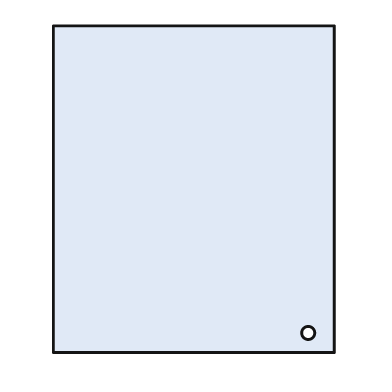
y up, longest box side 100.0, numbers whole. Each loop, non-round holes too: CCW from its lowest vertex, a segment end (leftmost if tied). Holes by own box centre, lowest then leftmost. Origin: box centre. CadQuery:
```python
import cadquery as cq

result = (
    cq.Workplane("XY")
    .moveTo(-43.0, -50.0)
    .lineTo(43.0, -50.0)
    .lineTo(43.0, 50.0)
    .lineTo(-43.0, 50.0)
    .close()
    .moveTo(35.0, -44.0)
    .circle(2.0)
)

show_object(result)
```